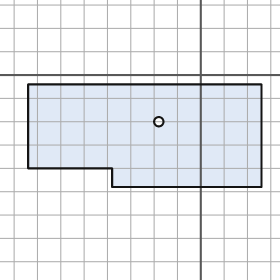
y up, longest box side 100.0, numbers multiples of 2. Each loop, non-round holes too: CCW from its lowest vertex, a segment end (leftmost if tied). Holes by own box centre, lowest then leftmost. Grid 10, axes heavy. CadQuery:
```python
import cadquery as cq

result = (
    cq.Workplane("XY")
    .moveTo(-38.0, -48.0)
    .lineTo(26.0, -48.0)
    .lineTo(26.0, -4.0)
    .lineTo(-74.0, -4.0)
    .lineTo(-74.0, -40.0)
    .lineTo(-38.0, -40.0)
    .close()
    .moveTo(-18.0, -20.0)
    .circle(2.0)
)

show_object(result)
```